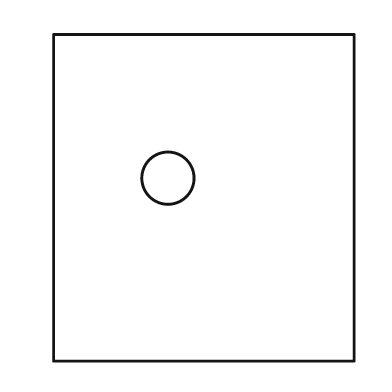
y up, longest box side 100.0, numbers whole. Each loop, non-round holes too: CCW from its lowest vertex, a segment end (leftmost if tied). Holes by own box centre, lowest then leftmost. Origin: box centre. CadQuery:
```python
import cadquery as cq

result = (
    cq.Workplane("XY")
    .moveTo(-46.0, -50.0)
    .lineTo(46.0, -50.0)
    .lineTo(46.0, 50.0)
    .lineTo(-46.0, 50.0)
    .close()
    .moveTo(-11.0, 6.0)
    .circle(8.0)
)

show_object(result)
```